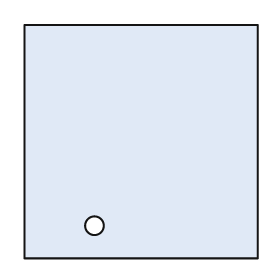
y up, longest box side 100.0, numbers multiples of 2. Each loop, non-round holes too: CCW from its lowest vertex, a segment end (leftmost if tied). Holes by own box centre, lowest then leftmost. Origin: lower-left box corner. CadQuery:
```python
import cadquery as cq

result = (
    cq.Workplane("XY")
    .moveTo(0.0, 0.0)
    .lineTo(100.0, 0.0)
    .lineTo(100.0, 100.0)
    .lineTo(0.0, 100.0)
    .close()
    .moveTo(30.0, 14.0)
    .circle(4.0)
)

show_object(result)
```